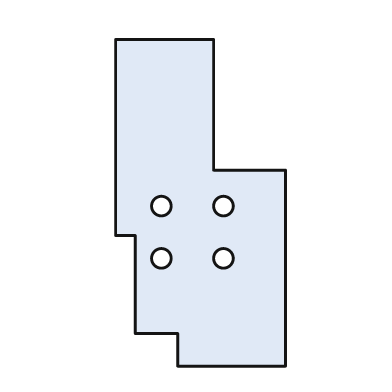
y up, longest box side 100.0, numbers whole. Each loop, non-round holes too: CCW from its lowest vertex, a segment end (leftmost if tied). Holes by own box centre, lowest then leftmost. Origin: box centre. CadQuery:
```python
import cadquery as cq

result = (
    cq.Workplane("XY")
    .moveTo(-7.0, -50.0)
    .lineTo(26.0, -50.0)
    .lineTo(26.0, 10.0)
    .lineTo(4.0, 10.0)
    .lineTo(4.0, 50.0)
    .lineTo(-26.0, 50.0)
    .lineTo(-26.0, -10.0)
    .lineTo(-20.0, -10.0)
    .lineTo(-20.0, -40.0)
    .lineTo(-7.0, -40.0)
    .close()
    .moveTo(-12.0, -17.0)
    .circle(3.0)
    .moveTo(7.0, -17.0)
    .circle(3.0)
    .moveTo(-12.0, -1.0)
    .circle(3.0)
    .moveTo(7.0, -1.0)
    .circle(3.0)
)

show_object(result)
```